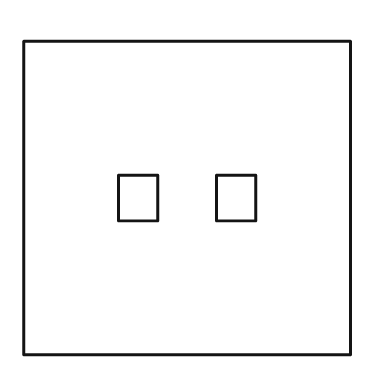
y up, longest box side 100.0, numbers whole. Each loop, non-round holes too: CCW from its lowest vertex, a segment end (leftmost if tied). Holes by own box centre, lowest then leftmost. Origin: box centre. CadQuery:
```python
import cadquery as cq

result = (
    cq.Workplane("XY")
    .moveTo(-50.0, -48.0)
    .lineTo(50.0, -48.0)
    .lineTo(50.0, 48.0)
    .lineTo(-50.0, 48.0)
    .close()
    .moveTo(-21.0, -7.0)
    .lineTo(-9.0, -7.0)
    .lineTo(-9.0, 7.0)
    .lineTo(-21.0, 7.0)
    .close()
    .moveTo(9.0, -7.0)
    .lineTo(21.0, -7.0)
    .lineTo(21.0, 7.0)
    .lineTo(9.0, 7.0)
    .close()
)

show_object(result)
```